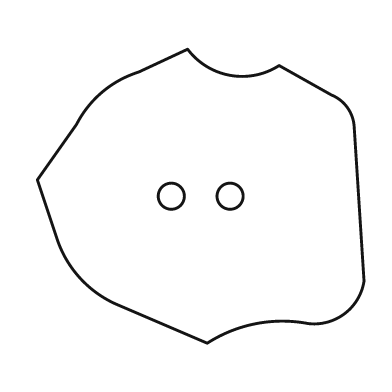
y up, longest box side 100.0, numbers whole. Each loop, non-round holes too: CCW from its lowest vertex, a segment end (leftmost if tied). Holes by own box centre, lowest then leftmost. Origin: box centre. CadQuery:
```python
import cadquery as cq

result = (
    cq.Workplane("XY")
    .moveTo(2.0, -45.0)
    .threePointArc((17.0, -39.0), (33.0, -39.0))
    .threePointArc((44.0, -36.0), (50.0, -26.0))
    .lineTo(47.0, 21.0)
    .threePointArc((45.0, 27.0), (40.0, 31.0))
    .lineTo(24.0, 40.0)
    .threePointArc((9.0, 37.0), (-4.0, 45.0))
    .lineTo(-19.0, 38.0)
    .threePointArc((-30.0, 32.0), (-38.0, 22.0))
    .lineTo(-50.0, 5.0)
    .lineTo(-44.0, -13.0)
    .threePointArc((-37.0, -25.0), (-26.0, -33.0))
    .close()
    .moveTo(-9.0, 0.0)
    .circle(4.0)
    .moveTo(9.0, 0.0)
    .circle(4.0)
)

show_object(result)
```